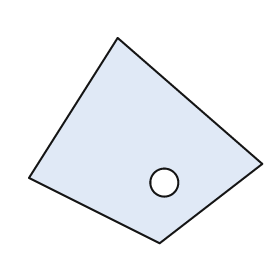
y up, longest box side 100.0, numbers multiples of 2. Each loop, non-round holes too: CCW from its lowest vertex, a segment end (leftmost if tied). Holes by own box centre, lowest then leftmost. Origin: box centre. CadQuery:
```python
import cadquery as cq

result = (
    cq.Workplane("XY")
    .moveTo(6.0, -44.0)
    .lineTo(50.0, -10.0)
    .lineTo(-12.0, 44.0)
    .lineTo(-50.0, -16.0)
    .close()
    .moveTo(8.0, -18.0)
    .circle(6.0)
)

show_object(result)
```